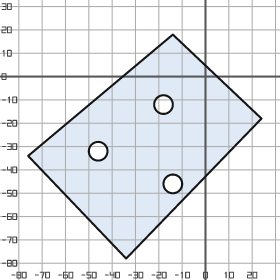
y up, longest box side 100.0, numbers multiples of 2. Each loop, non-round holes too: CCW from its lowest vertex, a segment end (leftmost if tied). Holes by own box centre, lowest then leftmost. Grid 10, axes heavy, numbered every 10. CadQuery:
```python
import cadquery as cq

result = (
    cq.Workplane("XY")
    .moveTo(-34.0, -78.0)
    .lineTo(24.0, -18.0)
    .lineTo(-14.0, 18.0)
    .lineTo(-76.0, -34.0)
    .close()
    .moveTo(-14.0, -46.0)
    .circle(4.0)
    .moveTo(-46.0, -32.0)
    .circle(4.0)
    .moveTo(-18.0, -12.0)
    .circle(4.0)
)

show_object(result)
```